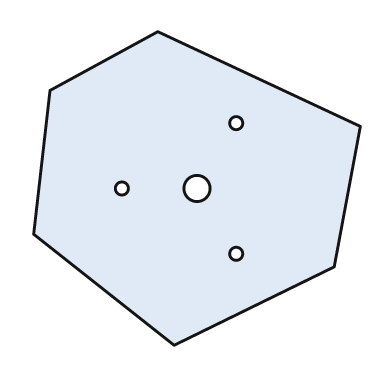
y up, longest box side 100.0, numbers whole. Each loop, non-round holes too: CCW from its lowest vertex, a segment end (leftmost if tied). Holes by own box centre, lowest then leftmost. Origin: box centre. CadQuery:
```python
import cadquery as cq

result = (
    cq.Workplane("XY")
    .moveTo(-7.0, -48.0)
    .lineTo(42.0, -24.0)
    .lineTo(50.0, 19.0)
    .lineTo(-12.0, 48.0)
    .lineTo(-45.0, 30.0)
    .lineTo(-50.0, -14.0)
    .close()
    .moveTo(12.0, -20.0)
    .circle(2.0)
    .moveTo(-23.0, 0.0)
    .circle(2.0)
    .moveTo(0.0, 0.0)
    .circle(4.0)
    .moveTo(12.0, 20.0)
    .circle(2.0)
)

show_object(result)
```